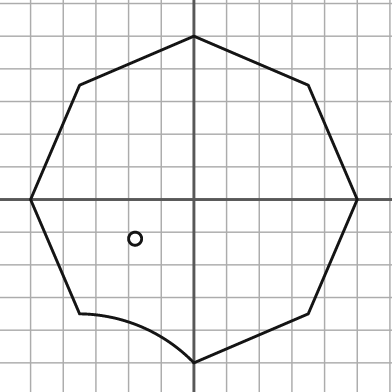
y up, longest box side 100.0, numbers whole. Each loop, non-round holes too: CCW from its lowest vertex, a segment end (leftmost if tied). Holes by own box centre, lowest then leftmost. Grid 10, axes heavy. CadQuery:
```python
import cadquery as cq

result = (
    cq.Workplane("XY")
    .moveTo(0.0, -50.0)
    .lineTo(35.0, -35.0)
    .lineTo(50.0, 0.0)
    .lineTo(35.0, 35.0)
    .lineTo(0.0, 50.0)
    .lineTo(-35.0, 35.0)
    .lineTo(-50.0, 0.0)
    .lineTo(-35.0, -35.0)
    .threePointArc((-16.0, -39.0), (0.0, -50.0))
    .close()
    .moveTo(-18.0, -12.0)
    .circle(2.0)
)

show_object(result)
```